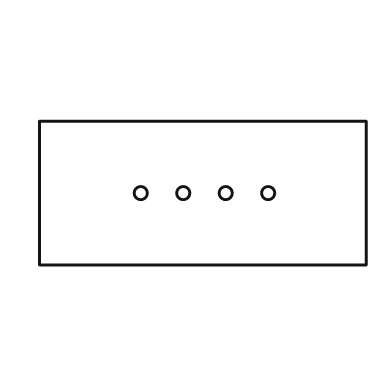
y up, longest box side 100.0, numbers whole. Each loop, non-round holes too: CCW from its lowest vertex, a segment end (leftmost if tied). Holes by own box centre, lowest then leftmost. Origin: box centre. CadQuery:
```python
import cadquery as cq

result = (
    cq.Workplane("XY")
    .moveTo(-50.0, -22.0)
    .lineTo(50.0, -22.0)
    .lineTo(50.0, 22.0)
    .lineTo(-50.0, 22.0)
    .close()
    .moveTo(-19.0, 0.0)
    .circle(2.0)
    .moveTo(-6.0, 0.0)
    .circle(2.0)
    .moveTo(7.0, 0.0)
    .circle(2.0)
    .moveTo(20.0, 0.0)
    .circle(2.0)
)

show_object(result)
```